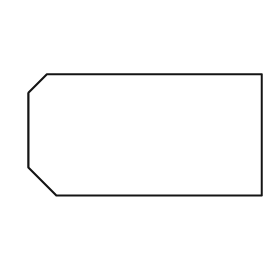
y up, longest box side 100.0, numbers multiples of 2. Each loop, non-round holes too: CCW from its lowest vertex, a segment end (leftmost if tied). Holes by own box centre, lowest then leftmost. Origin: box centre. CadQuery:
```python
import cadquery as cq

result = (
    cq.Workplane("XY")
    .moveTo(-38.0, -26.0)
    .lineTo(50.0, -26.0)
    .lineTo(50.0, 26.0)
    .lineTo(-42.0, 26.0)
    .lineTo(-50.0, 18.0)
    .lineTo(-50.0, -14.0)
    .close()
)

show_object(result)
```